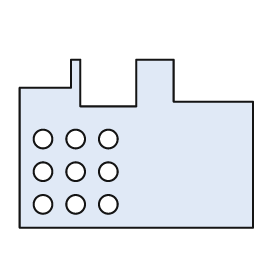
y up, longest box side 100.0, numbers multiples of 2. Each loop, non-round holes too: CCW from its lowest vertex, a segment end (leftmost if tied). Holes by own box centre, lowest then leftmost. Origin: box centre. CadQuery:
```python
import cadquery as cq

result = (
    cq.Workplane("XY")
    .moveTo(-50.0, -36.0)
    .lineTo(50.0, -36.0)
    .lineTo(50.0, 18.0)
    .lineTo(16.0, 18.0)
    .lineTo(16.0, 36.0)
    .lineTo(0.0, 36.0)
    .lineTo(0.0, 16.0)
    .lineTo(-24.0, 16.0)
    .lineTo(-24.0, 36.0)
    .lineTo(-28.0, 36.0)
    .lineTo(-28.0, 24.0)
    .lineTo(-50.0, 24.0)
    .close()
    .moveTo(-40.0, -26.0)
    .circle(4.0)
    .moveTo(-26.0, -26.0)
    .circle(4.0)
    .moveTo(-12.0, -26.0)
    .circle(4.0)
    .moveTo(-40.0, -12.0)
    .circle(4.0)
    .moveTo(-26.0, -12.0)
    .circle(4.0)
    .moveTo(-12.0, -12.0)
    .circle(4.0)
    .moveTo(-40.0, 2.0)
    .circle(4.0)
    .moveTo(-26.0, 2.0)
    .circle(4.0)
    .moveTo(-12.0, 2.0)
    .circle(4.0)
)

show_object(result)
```